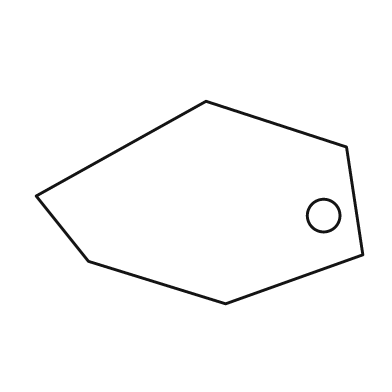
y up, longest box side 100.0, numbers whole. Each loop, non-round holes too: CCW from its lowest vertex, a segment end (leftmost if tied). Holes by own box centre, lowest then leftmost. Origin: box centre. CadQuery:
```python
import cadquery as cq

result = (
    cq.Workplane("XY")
    .moveTo(8.0, -31.0)
    .lineTo(50.0, -16.0)
    .lineTo(45.0, 17.0)
    .lineTo(2.0, 31.0)
    .lineTo(-50.0, 2.0)
    .lineTo(-34.0, -18.0)
    .close()
    .moveTo(38.0, -4.0)
    .circle(5.0)
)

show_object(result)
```